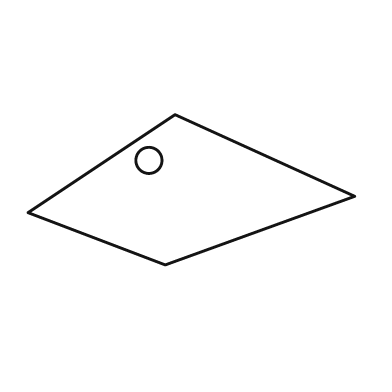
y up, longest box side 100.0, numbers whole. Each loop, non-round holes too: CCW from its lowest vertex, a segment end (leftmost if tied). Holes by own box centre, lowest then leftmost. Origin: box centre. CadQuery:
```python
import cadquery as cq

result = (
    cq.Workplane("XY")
    .moveTo(-8.0, -23.0)
    .lineTo(50.0, -2.0)
    .lineTo(-5.0, 23.0)
    .lineTo(-50.0, -7.0)
    .close()
    .moveTo(-13.0, 9.0)
    .circle(4.0)
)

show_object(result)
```